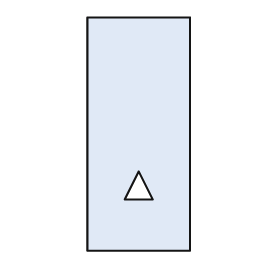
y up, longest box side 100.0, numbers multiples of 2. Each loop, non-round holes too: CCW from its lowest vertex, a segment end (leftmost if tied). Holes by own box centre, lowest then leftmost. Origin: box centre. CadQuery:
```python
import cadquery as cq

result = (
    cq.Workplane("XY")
    .moveTo(-22.0, -50.0)
    .lineTo(22.0, -50.0)
    .lineTo(22.0, 50.0)
    .lineTo(-22.0, 50.0)
    .close()
    .moveTo(-6.0, -28.0)
    .lineTo(6.0, -28.0)
    .lineTo(0.0, -16.0)
    .close()
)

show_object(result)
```